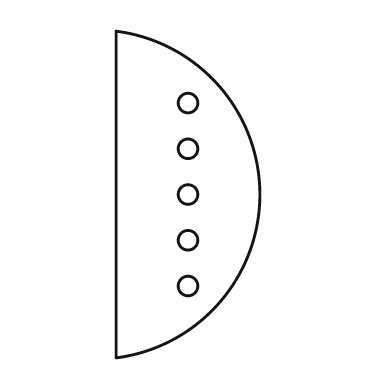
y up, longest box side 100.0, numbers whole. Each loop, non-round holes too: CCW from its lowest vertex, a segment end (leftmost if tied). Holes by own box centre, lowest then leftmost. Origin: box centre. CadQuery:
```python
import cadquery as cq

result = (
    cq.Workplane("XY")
    .moveTo(-22.0, -50.0)
    .threePointArc((22.0, 0.0), (-22.0, 50.0))
    .close()
    .moveTo(0.0, -28.0)
    .circle(3.0)
    .moveTo(0.0, -14.0)
    .circle(3.0)
    .moveTo(0.0, 0.0)
    .circle(3.0)
    .moveTo(0.0, 14.0)
    .circle(3.0)
    .moveTo(0.0, 28.0)
    .circle(3.0)
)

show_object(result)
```